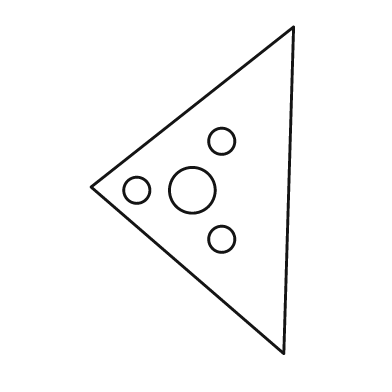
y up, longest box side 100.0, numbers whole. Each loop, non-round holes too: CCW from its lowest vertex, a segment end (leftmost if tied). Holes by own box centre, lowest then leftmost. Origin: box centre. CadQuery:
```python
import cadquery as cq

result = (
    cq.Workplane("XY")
    .moveTo(28.0, -50.0)
    .lineTo(31.0, 50.0)
    .lineTo(-31.0, 1.0)
    .close()
    .moveTo(9.0, -15.0)
    .circle(4.0)
    .moveTo(-17.0, 0.0)
    .circle(4.0)
    .moveTo(0.0, 0.0)
    .circle(7.0)
    .moveTo(9.0, 15.0)
    .circle(4.0)
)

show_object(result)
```